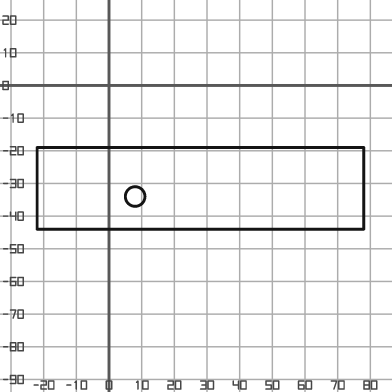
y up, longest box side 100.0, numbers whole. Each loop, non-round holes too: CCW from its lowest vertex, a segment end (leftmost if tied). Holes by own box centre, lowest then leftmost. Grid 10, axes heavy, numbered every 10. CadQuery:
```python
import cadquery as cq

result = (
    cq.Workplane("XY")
    .moveTo(-22.0, -44.0)
    .lineTo(78.0, -44.0)
    .lineTo(78.0, -19.0)
    .lineTo(-22.0, -19.0)
    .close()
    .moveTo(8.0, -34.0)
    .circle(3.0)
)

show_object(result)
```